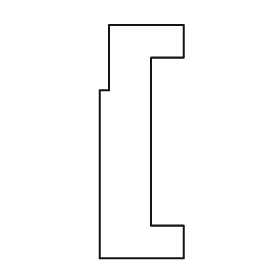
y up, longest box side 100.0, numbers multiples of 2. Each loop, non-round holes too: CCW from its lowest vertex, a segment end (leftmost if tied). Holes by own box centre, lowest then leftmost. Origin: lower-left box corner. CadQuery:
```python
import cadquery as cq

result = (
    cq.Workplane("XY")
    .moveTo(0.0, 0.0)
    .lineTo(36.0, 0.0)
    .lineTo(36.0, 14.0)
    .lineTo(22.0, 14.0)
    .lineTo(22.0, 86.0)
    .lineTo(36.0, 86.0)
    .lineTo(36.0, 100.0)
    .lineTo(4.0, 100.0)
    .lineTo(4.0, 72.0)
    .lineTo(0.0, 72.0)
    .close()
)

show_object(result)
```